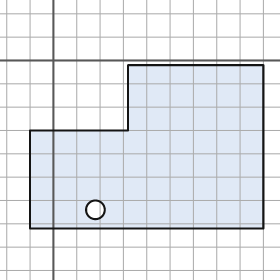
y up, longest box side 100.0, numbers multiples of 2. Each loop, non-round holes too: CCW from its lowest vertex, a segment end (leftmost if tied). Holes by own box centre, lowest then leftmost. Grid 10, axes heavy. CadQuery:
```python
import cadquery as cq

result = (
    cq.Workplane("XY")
    .moveTo(-10.0, -72.0)
    .lineTo(90.0, -72.0)
    .lineTo(90.0, -2.0)
    .lineTo(32.0, -2.0)
    .lineTo(32.0, -30.0)
    .lineTo(-10.0, -30.0)
    .close()
    .moveTo(18.0, -64.0)
    .circle(4.0)
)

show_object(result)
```